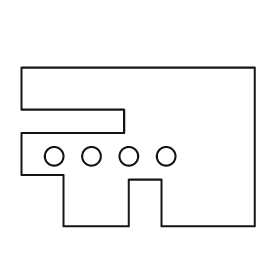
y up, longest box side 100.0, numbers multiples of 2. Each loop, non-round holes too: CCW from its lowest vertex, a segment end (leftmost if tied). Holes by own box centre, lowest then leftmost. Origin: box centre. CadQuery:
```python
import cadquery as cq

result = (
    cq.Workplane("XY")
    .moveTo(-32.0, -34.0)
    .lineTo(-4.0, -34.0)
    .lineTo(-4.0, -14.0)
    .lineTo(10.0, -14.0)
    .lineTo(10.0, -34.0)
    .lineTo(50.0, -34.0)
    .lineTo(50.0, 34.0)
    .lineTo(-50.0, 34.0)
    .lineTo(-50.0, 16.0)
    .lineTo(-6.0, 16.0)
    .lineTo(-6.0, 6.0)
    .lineTo(-50.0, 6.0)
    .lineTo(-50.0, -12.0)
    .lineTo(-32.0, -12.0)
    .close()
    .moveTo(-36.0, -4.0)
    .circle(4.0)
    .moveTo(-20.0, -4.0)
    .circle(4.0)
    .moveTo(-4.0, -4.0)
    .circle(4.0)
    .moveTo(12.0, -4.0)
    .circle(4.0)
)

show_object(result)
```